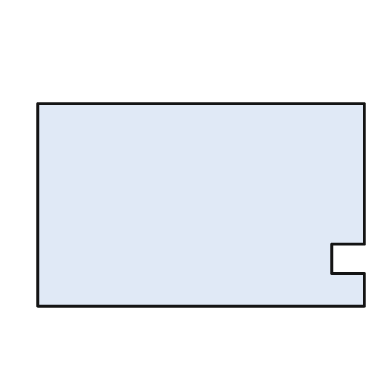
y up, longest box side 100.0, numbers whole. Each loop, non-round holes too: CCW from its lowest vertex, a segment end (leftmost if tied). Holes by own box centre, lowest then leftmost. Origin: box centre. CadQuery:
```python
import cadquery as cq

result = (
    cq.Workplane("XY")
    .moveTo(-50.0, -31.0)
    .lineTo(50.0, -31.0)
    .lineTo(50.0, -21.0)
    .lineTo(40.0, -21.0)
    .lineTo(40.0, -12.0)
    .lineTo(50.0, -12.0)
    .lineTo(50.0, 31.0)
    .lineTo(-50.0, 31.0)
    .close()
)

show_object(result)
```